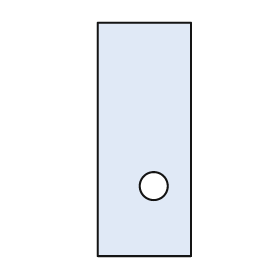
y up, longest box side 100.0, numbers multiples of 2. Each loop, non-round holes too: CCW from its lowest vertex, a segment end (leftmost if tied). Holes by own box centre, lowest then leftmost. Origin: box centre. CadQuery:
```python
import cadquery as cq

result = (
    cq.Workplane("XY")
    .moveTo(-20.0, -50.0)
    .lineTo(20.0, -50.0)
    .lineTo(20.0, 50.0)
    .lineTo(-20.0, 50.0)
    .close()
    .moveTo(4.0, -20.0)
    .circle(6.0)
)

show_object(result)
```